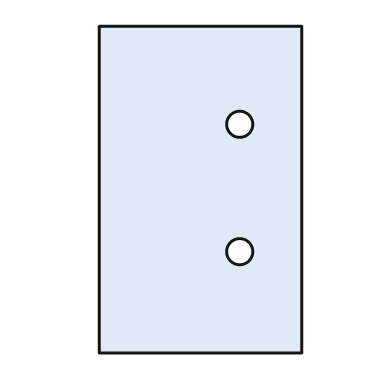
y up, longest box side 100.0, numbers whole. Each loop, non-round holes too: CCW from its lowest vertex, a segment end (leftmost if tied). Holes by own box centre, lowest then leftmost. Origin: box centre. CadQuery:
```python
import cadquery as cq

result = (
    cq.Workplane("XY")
    .moveTo(-31.0, -50.0)
    .lineTo(31.0, -50.0)
    .lineTo(31.0, 50.0)
    .lineTo(-31.0, 50.0)
    .close()
    .moveTo(12.0, -19.0)
    .circle(4.0)
    .moveTo(12.0, 20.0)
    .circle(4.0)
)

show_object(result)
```